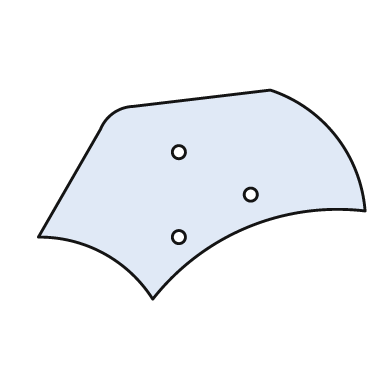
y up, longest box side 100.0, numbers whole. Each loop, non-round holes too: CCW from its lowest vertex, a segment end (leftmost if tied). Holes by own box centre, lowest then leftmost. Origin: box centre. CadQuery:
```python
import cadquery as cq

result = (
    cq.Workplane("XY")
    .moveTo(-15.0, -32.0)
    .threePointArc((14.0, -10.0), (50.0, -5.0))
    .threePointArc((41.0, 18.0), (21.0, 32.0))
    .lineTo(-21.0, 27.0)
    .threePointArc((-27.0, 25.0), (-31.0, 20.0))
    .lineTo(-50.0, -13.0)
    .threePointArc((-30.0, -18.0), (-15.0, -32.0))
    .close()
    .moveTo(-7.0, -13.0)
    .circle(2.0)
    .moveTo(15.0, 0.0)
    .circle(2.0)
    .moveTo(-7.0, 13.0)
    .circle(2.0)
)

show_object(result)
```